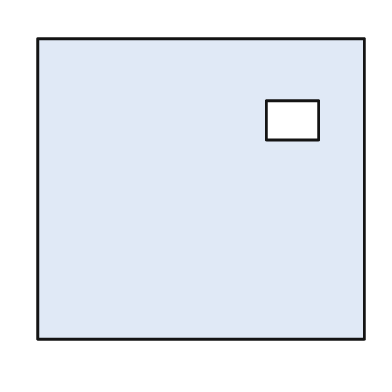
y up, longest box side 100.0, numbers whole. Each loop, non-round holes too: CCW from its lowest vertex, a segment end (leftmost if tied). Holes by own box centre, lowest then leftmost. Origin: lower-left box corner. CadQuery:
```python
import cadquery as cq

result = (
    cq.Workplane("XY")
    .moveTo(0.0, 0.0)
    .lineTo(100.0, 0.0)
    .lineTo(100.0, 92.0)
    .lineTo(0.0, 92.0)
    .close()
    .moveTo(70.0, 61.0)
    .lineTo(86.0, 61.0)
    .lineTo(86.0, 73.0)
    .lineTo(70.0, 73.0)
    .close()
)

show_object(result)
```